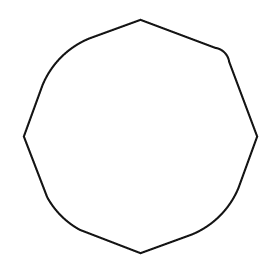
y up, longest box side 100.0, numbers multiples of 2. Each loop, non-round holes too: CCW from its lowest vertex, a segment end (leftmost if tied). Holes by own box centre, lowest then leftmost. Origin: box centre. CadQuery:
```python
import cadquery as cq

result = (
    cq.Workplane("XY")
    .moveTo(0.0, -50.0)
    .lineTo(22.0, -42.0)
    .threePointArc((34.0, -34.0), (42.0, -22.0))
    .lineTo(50.0, 0.0)
    .lineTo(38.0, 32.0)
    .threePointArc((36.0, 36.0), (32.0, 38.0))
    .lineTo(0.0, 50.0)
    .lineTo(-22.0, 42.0)
    .threePointArc((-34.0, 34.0), (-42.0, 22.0))
    .lineTo(-50.0, 0.0)
    .lineTo(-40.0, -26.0)
    .threePointArc((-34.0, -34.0), (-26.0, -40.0))
    .close()
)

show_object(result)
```